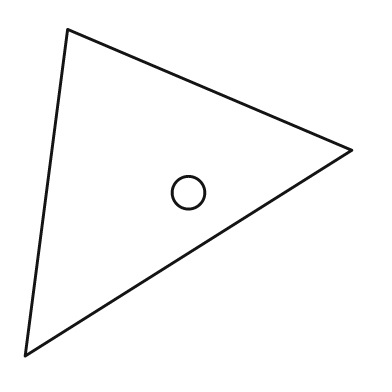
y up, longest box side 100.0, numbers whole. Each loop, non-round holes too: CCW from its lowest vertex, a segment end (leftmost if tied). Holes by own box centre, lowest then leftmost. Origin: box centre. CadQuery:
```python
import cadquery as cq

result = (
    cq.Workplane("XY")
    .moveTo(-50.0, -50.0)
    .lineTo(50.0, 13.0)
    .lineTo(-37.0, 50.0)
    .close()
    .moveTo(0.0, 0.0)
    .circle(5.0)
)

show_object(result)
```